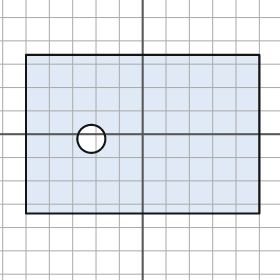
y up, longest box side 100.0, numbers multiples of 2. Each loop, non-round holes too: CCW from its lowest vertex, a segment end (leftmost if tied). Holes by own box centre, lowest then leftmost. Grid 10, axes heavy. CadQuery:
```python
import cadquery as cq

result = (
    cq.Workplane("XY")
    .moveTo(-50.0, -34.0)
    .lineTo(50.0, -34.0)
    .lineTo(50.0, 34.0)
    .lineTo(-50.0, 34.0)
    .close()
    .moveTo(-22.0, -2.0)
    .circle(6.0)
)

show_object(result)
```